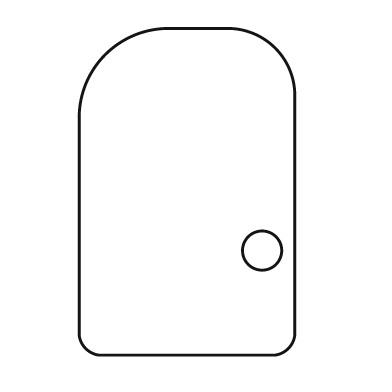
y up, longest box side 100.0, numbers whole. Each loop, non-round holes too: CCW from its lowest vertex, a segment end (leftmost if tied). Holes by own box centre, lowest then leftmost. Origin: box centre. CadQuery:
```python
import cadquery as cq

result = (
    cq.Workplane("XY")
    .moveTo(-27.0, -50.0)
    .lineTo(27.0, -50.0)
    .threePointArc((31.0, -48.0), (33.0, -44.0))
    .lineTo(33.0, 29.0)
    .threePointArc((27.0, 44.0), (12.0, 50.0))
    .lineTo(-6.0, 50.0)
    .threePointArc((-25.0, 42.0), (-33.0, 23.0))
    .lineTo(-33.0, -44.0)
    .threePointArc((-31.0, -48.0), (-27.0, -50.0))
    .close()
    .moveTo(23.0, -18.0)
    .circle(6.0)
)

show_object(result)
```